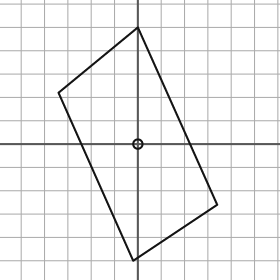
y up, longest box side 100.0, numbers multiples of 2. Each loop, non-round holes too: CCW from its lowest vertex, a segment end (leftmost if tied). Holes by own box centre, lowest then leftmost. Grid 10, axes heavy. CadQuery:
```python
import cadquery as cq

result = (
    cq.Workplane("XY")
    .moveTo(-2.0, -50.0)
    .lineTo(34.0, -26.0)
    .lineTo(0.0, 50.0)
    .lineTo(-34.0, 22.0)
    .close()
    .moveTo(0.0, 0.0)
    .circle(2.0)
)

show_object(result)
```